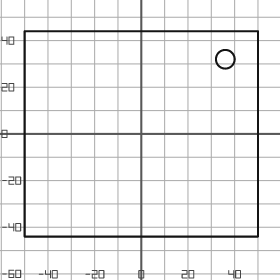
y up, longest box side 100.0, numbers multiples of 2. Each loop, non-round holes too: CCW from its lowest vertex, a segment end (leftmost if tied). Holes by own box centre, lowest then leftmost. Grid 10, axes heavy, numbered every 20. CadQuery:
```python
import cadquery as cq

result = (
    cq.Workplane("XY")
    .moveTo(-50.0, -44.0)
    .lineTo(50.0, -44.0)
    .lineTo(50.0, 44.0)
    .lineTo(-50.0, 44.0)
    .close()
    .moveTo(36.0, 32.0)
    .circle(4.0)
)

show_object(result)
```